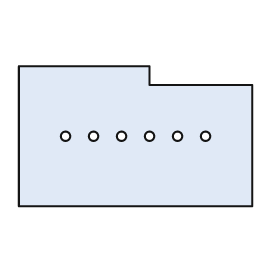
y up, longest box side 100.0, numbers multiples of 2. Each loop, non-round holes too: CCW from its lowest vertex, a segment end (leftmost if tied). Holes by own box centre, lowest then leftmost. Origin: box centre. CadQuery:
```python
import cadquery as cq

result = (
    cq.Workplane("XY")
    .moveTo(-50.0, -30.0)
    .lineTo(50.0, -30.0)
    .lineTo(50.0, 22.0)
    .lineTo(6.0, 22.0)
    .lineTo(6.0, 30.0)
    .lineTo(-50.0, 30.0)
    .close()
    .moveTo(-30.0, 0.0)
    .circle(2.0)
    .moveTo(-18.0, 0.0)
    .circle(2.0)
    .moveTo(-6.0, 0.0)
    .circle(2.0)
    .moveTo(6.0, 0.0)
    .circle(2.0)
    .moveTo(18.0, 0.0)
    .circle(2.0)
    .moveTo(30.0, 0.0)
    .circle(2.0)
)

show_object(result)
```